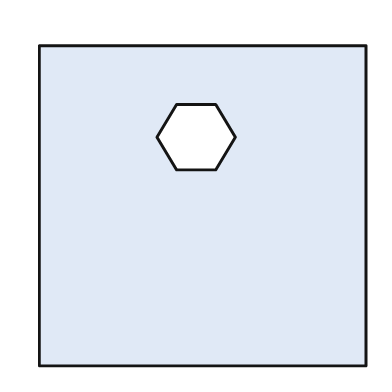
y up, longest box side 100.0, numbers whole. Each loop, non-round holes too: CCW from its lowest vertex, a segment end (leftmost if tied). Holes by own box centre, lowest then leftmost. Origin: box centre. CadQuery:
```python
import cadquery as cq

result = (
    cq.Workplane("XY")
    .moveTo(-50.0, -49.0)
    .lineTo(50.0, -49.0)
    .lineTo(50.0, 49.0)
    .lineTo(-50.0, 49.0)
    .close()
    .moveTo(-8.0, 11.0)
    .lineTo(4.0, 11.0)
    .lineTo(10.0, 21.0)
    .lineTo(4.0, 31.0)
    .lineTo(-8.0, 31.0)
    .lineTo(-14.0, 21.0)
    .close()
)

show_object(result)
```